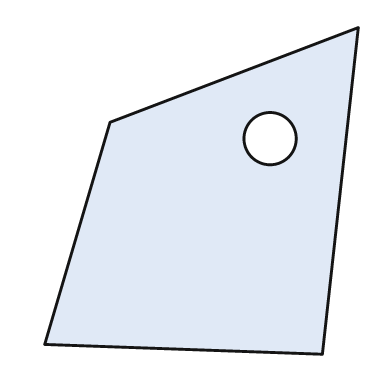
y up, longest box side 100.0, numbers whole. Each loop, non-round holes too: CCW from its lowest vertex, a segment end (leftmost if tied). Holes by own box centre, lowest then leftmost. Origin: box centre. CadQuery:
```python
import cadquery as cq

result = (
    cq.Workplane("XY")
    .moveTo(37.0, -50.0)
    .lineTo(48.0, 50.0)
    .lineTo(-28.0, 21.0)
    .lineTo(-48.0, -47.0)
    .close()
    .moveTo(21.0, 16.0)
    .circle(8.0)
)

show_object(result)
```